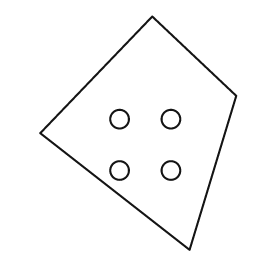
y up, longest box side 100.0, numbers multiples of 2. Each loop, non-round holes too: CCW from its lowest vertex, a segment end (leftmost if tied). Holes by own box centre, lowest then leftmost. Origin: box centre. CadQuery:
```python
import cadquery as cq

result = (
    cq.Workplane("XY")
    .moveTo(22.0, -50.0)
    .lineTo(42.0, 16.0)
    .lineTo(6.0, 50.0)
    .lineTo(-42.0, 0.0)
    .close()
    .moveTo(-8.0, -16.0)
    .circle(4.0)
    .moveTo(14.0, -16.0)
    .circle(4.0)
    .moveTo(-8.0, 6.0)
    .circle(4.0)
    .moveTo(14.0, 6.0)
    .circle(4.0)
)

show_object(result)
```